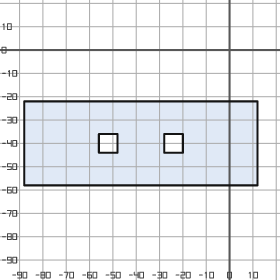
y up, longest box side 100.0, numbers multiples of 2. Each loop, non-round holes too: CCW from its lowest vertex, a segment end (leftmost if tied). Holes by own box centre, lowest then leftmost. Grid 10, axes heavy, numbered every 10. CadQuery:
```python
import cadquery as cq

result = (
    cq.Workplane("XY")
    .moveTo(-88.0, -58.0)
    .lineTo(12.0, -58.0)
    .lineTo(12.0, -22.0)
    .lineTo(-88.0, -22.0)
    .close()
    .moveTo(-56.0, -44.0)
    .lineTo(-48.0, -44.0)
    .lineTo(-48.0, -36.0)
    .lineTo(-56.0, -36.0)
    .close()
    .moveTo(-28.0, -44.0)
    .lineTo(-20.0, -44.0)
    .lineTo(-20.0, -36.0)
    .lineTo(-28.0, -36.0)
    .close()
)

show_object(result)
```